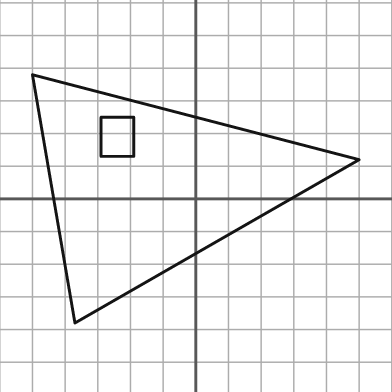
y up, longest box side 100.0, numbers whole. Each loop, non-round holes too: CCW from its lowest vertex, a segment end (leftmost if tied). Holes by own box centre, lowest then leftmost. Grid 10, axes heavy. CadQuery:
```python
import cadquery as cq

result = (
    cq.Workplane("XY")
    .moveTo(-37.0, -38.0)
    .lineTo(50.0, 12.0)
    .lineTo(-50.0, 38.0)
    .close()
    .moveTo(-29.0, 13.0)
    .lineTo(-19.0, 13.0)
    .lineTo(-19.0, 25.0)
    .lineTo(-29.0, 25.0)
    .close()
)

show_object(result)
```